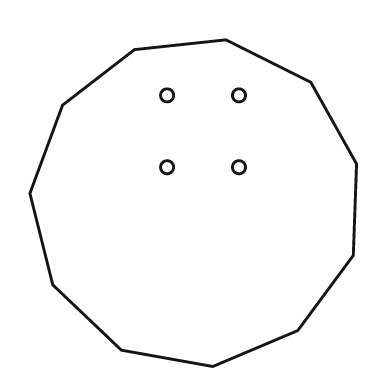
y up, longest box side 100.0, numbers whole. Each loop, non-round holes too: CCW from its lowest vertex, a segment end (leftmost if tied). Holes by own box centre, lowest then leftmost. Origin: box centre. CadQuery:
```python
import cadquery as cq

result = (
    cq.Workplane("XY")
    .moveTo(6.0, -50.0)
    .lineTo(32.0, -39.0)
    .lineTo(49.0, -16.0)
    .lineTo(50.0, 12.0)
    .lineTo(36.0, 37.0)
    .lineTo(10.0, 50.0)
    .lineTo(-18.0, 47.0)
    .lineTo(-40.0, 30.0)
    .lineTo(-50.0, 3.0)
    .lineTo(-43.0, -25.0)
    .lineTo(-22.0, -45.0)
    .close()
    .moveTo(-8.0, 11.0)
    .circle(2.0)
    .moveTo(14.0, 11.0)
    .circle(2.0)
    .moveTo(-8.0, 33.0)
    .circle(2.0)
    .moveTo(14.0, 33.0)
    .circle(2.0)
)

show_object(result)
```